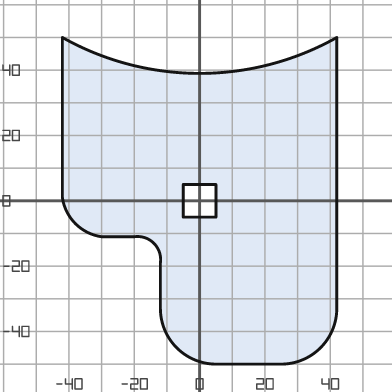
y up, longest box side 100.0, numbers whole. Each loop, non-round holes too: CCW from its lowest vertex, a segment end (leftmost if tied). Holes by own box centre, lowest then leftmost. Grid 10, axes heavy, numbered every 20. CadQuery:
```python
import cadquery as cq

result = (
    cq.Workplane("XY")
    .moveTo(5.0, -50.0)
    .lineTo(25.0, -50.0)
    .threePointArc((37.0, -45.0), (42.0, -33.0))
    .lineTo(42.0, 50.0)
    .threePointArc((0.0, 39.0), (-42.0, 50.0))
    .lineTo(-42.0, 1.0)
    .threePointArc((-38.0, -7.0), (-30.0, -11.0))
    .lineTo(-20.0, -11.0)
    .threePointArc((-14.0, -13.0), (-12.0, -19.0))
    .lineTo(-12.0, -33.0)
    .threePointArc((-7.0, -45.0), (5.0, -50.0))
    .close()
    .moveTo(-5.0, -5.0)
    .lineTo(5.0, -5.0)
    .lineTo(5.0, 5.0)
    .lineTo(-5.0, 5.0)
    .close()
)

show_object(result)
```